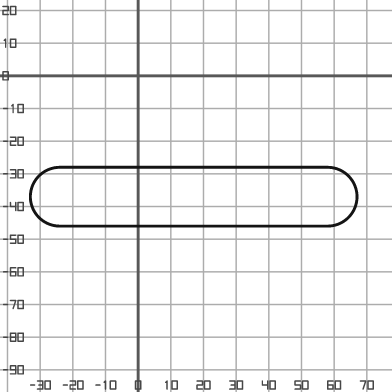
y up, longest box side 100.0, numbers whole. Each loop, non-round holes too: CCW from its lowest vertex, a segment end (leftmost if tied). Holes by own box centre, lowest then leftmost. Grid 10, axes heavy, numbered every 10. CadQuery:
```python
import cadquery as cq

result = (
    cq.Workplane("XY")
    .moveTo(-24.0, -46.0)
    .lineTo(58.0, -46.0)
    .threePointArc((67.0, -37.0), (58.0, -28.0))
    .lineTo(-24.0, -28.0)
    .threePointArc((-33.0, -37.0), (-24.0, -46.0))
    .close()
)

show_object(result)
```